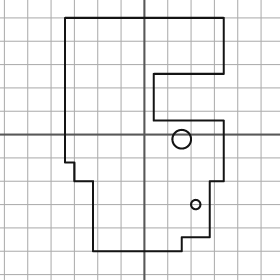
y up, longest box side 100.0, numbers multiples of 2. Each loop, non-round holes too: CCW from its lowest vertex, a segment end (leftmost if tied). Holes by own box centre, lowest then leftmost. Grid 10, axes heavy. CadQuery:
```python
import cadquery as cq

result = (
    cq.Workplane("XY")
    .moveTo(-22.0, -50.0)
    .lineTo(16.0, -50.0)
    .lineTo(16.0, -44.0)
    .lineTo(28.0, -44.0)
    .lineTo(28.0, -20.0)
    .lineTo(34.0, -20.0)
    .lineTo(34.0, 6.0)
    .lineTo(4.0, 6.0)
    .lineTo(4.0, 26.0)
    .lineTo(34.0, 26.0)
    .lineTo(34.0, 50.0)
    .lineTo(-34.0, 50.0)
    .lineTo(-34.0, -12.0)
    .lineTo(-30.0, -12.0)
    .lineTo(-30.0, -20.0)
    .lineTo(-22.0, -20.0)
    .close()
    .moveTo(22.0, -30.0)
    .circle(2.0)
    .moveTo(16.0, -2.0)
    .circle(4.0)
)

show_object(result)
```